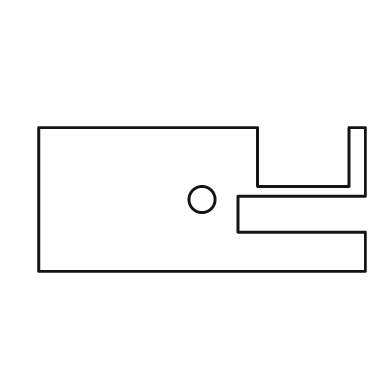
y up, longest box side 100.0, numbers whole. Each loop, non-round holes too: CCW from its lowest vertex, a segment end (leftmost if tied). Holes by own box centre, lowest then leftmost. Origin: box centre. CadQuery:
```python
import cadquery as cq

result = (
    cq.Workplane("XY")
    .moveTo(-50.0, -22.0)
    .lineTo(50.0, -22.0)
    .lineTo(50.0, -10.0)
    .lineTo(11.0, -10.0)
    .lineTo(11.0, 1.0)
    .lineTo(50.0, 1.0)
    .lineTo(50.0, 22.0)
    .lineTo(45.0, 22.0)
    .lineTo(45.0, 4.0)
    .lineTo(17.0, 4.0)
    .lineTo(17.0, 22.0)
    .lineTo(-50.0, 22.0)
    .close()
    .moveTo(0.0, 0.0)
    .circle(4.0)
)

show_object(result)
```